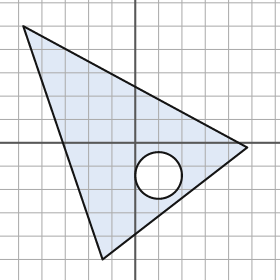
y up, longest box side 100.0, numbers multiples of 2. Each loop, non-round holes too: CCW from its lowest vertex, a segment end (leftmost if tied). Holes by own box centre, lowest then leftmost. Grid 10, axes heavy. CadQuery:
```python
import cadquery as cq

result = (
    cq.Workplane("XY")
    .moveTo(-14.0, -50.0)
    .lineTo(48.0, -2.0)
    .lineTo(-48.0, 50.0)
    .close()
    .moveTo(10.0, -14.0)
    .circle(10.0)
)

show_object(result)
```